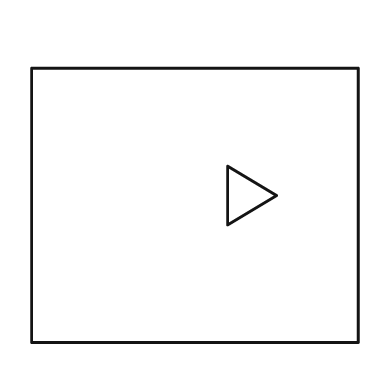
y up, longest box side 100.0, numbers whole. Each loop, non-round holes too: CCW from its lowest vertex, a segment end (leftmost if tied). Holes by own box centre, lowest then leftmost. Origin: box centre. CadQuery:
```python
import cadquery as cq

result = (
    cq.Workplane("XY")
    .moveTo(-50.0, -42.0)
    .lineTo(50.0, -42.0)
    .lineTo(50.0, 42.0)
    .lineTo(-50.0, 42.0)
    .close()
    .moveTo(10.0, -6.0)
    .lineTo(25.0, 3.0)
    .lineTo(10.0, 12.0)
    .close()
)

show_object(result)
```